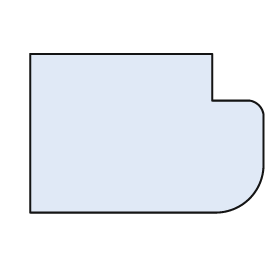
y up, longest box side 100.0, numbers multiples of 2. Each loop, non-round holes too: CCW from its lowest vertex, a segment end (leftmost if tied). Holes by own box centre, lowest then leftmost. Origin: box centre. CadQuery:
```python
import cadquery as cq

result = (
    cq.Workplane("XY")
    .moveTo(-50.0, -34.0)
    .lineTo(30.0, -34.0)
    .threePointArc((44.0, -28.0), (50.0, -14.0))
    .lineTo(50.0, 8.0)
    .threePointArc((48.0, 12.0), (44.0, 14.0))
    .lineTo(28.0, 14.0)
    .lineTo(28.0, 34.0)
    .lineTo(-50.0, 34.0)
    .close()
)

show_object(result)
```